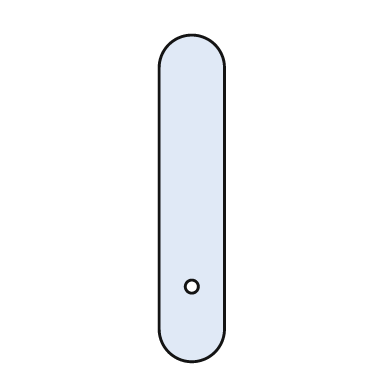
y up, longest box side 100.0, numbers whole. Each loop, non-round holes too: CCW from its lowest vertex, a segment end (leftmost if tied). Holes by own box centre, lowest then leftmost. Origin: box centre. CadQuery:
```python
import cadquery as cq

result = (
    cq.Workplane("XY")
    .moveTo(-10.0, -40.0)
    .threePointArc((0.0, -50.0), (10.0, -40.0))
    .lineTo(10.0, 40.0)
    .threePointArc((0.0, 50.0), (-10.0, 40.0))
    .close()
    .moveTo(0.0, -27.0)
    .circle(2.0)
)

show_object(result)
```